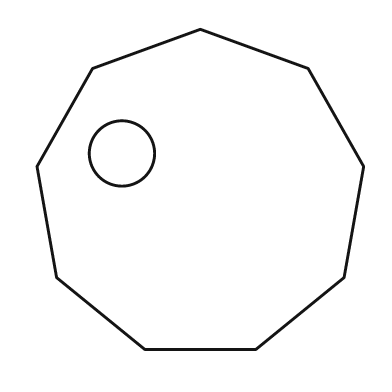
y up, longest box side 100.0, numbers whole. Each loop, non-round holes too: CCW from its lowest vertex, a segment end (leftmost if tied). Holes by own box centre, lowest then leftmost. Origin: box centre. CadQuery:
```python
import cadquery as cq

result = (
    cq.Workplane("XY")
    .moveTo(-17.0, -49.0)
    .lineTo(17.0, -49.0)
    .lineTo(44.0, -27.0)
    .lineTo(50.0, 7.0)
    .lineTo(33.0, 37.0)
    .lineTo(0.0, 49.0)
    .lineTo(-33.0, 37.0)
    .lineTo(-50.0, 7.0)
    .lineTo(-44.0, -27.0)
    .close()
    .moveTo(-24.0, 11.0)
    .circle(10.0)
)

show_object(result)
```